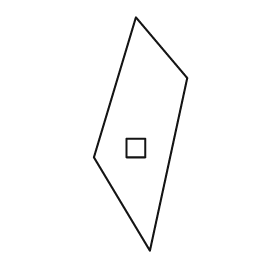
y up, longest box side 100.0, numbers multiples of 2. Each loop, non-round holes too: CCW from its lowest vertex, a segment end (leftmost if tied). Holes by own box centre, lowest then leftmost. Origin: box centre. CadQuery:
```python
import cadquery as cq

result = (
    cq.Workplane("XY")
    .moveTo(4.0, -50.0)
    .lineTo(20.0, 24.0)
    .lineTo(-2.0, 50.0)
    .lineTo(-20.0, -10.0)
    .close()
    .moveTo(-6.0, -10.0)
    .lineTo(2.0, -10.0)
    .lineTo(2.0, -2.0)
    .lineTo(-6.0, -2.0)
    .close()
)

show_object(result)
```